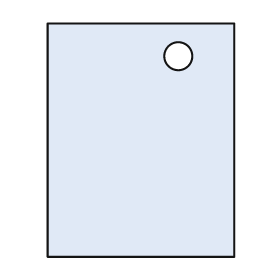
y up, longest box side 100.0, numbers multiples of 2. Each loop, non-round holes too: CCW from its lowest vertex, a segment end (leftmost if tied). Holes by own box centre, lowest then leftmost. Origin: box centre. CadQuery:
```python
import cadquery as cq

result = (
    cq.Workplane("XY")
    .moveTo(-40.0, -50.0)
    .lineTo(40.0, -50.0)
    .lineTo(40.0, 50.0)
    .lineTo(-40.0, 50.0)
    .close()
    .moveTo(16.0, 36.0)
    .circle(6.0)
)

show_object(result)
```